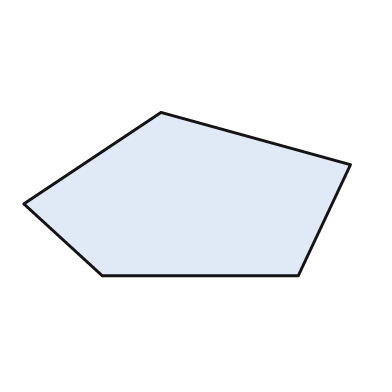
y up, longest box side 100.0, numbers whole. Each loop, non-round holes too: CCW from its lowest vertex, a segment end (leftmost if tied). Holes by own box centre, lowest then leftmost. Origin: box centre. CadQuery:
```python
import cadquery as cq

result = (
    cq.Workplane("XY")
    .moveTo(-26.0, -25.0)
    .lineTo(34.0, -25.0)
    .lineTo(50.0, 9.0)
    .lineTo(-8.0, 25.0)
    .lineTo(-50.0, -3.0)
    .close()
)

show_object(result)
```